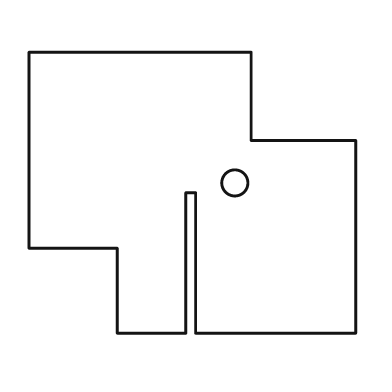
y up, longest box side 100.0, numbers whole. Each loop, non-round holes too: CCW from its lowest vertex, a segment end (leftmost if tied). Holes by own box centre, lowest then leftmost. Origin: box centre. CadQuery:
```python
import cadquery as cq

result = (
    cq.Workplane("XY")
    .moveTo(-23.0, -43.0)
    .lineTo(-2.0, -43.0)
    .lineTo(-2.0, 0.0)
    .lineTo(1.0, 0.0)
    .lineTo(1.0, -43.0)
    .lineTo(50.0, -43.0)
    .lineTo(50.0, 16.0)
    .lineTo(18.0, 16.0)
    .lineTo(18.0, 43.0)
    .lineTo(-50.0, 43.0)
    .lineTo(-50.0, -17.0)
    .lineTo(-23.0, -17.0)
    .close()
    .moveTo(13.0, 3.0)
    .circle(4.0)
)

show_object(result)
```